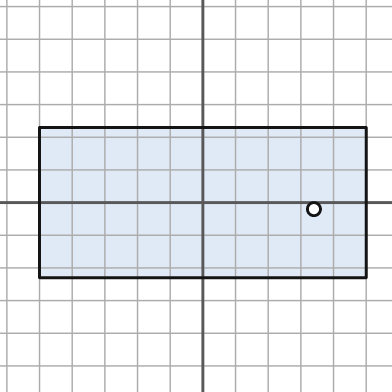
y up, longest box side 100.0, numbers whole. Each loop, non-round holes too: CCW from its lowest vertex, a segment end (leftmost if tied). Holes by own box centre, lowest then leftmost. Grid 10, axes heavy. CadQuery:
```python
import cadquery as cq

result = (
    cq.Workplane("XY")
    .moveTo(-50.0, -23.0)
    .lineTo(50.0, -23.0)
    .lineTo(50.0, 23.0)
    .lineTo(-50.0, 23.0)
    .close()
    .moveTo(34.0, -2.0)
    .circle(2.0)
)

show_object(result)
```